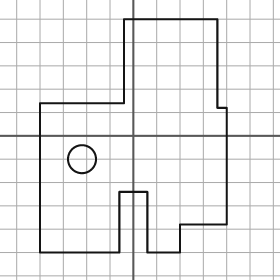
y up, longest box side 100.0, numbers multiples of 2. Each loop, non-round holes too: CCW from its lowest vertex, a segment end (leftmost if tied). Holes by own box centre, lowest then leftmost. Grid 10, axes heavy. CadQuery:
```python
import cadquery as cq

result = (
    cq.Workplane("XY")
    .moveTo(-40.0, -50.0)
    .lineTo(-6.0, -50.0)
    .lineTo(-6.0, -24.0)
    .lineTo(6.0, -24.0)
    .lineTo(6.0, -50.0)
    .lineTo(20.0, -50.0)
    .lineTo(20.0, -38.0)
    .lineTo(40.0, -38.0)
    .lineTo(40.0, 12.0)
    .lineTo(36.0, 12.0)
    .lineTo(36.0, 50.0)
    .lineTo(-4.0, 50.0)
    .lineTo(-4.0, 14.0)
    .lineTo(-40.0, 14.0)
    .close()
    .moveTo(-22.0, -10.0)
    .circle(6.0)
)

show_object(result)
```